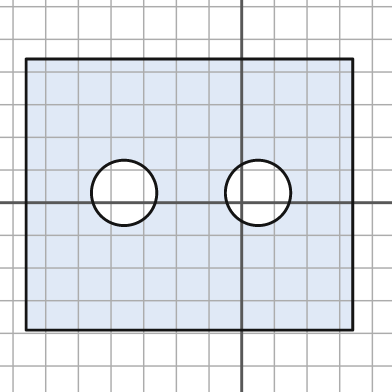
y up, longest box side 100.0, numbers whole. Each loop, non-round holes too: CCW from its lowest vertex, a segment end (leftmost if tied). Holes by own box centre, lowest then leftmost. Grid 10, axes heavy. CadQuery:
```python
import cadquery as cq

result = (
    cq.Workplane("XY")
    .moveTo(-66.0, -39.0)
    .lineTo(34.0, -39.0)
    .lineTo(34.0, 44.0)
    .lineTo(-66.0, 44.0)
    .close()
    .moveTo(-36.0, 3.0)
    .circle(10.0)
    .moveTo(5.0, 3.0)
    .circle(10.0)
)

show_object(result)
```